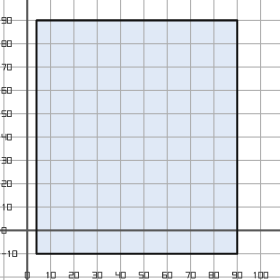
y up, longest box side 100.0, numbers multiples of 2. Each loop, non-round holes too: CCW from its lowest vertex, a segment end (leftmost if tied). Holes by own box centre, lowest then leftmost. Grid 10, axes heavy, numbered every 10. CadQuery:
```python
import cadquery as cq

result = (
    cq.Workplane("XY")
    .moveTo(4.0, -10.0)
    .lineTo(90.0, -10.0)
    .lineTo(90.0, 90.0)
    .lineTo(4.0, 90.0)
    .close()
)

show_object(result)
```